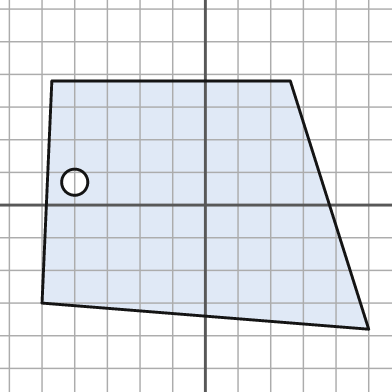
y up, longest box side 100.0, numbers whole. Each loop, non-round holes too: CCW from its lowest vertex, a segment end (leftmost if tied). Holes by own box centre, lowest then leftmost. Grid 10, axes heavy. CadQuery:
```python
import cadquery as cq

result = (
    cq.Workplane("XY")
    .moveTo(50.0, -38.0)
    .lineTo(26.0, 38.0)
    .lineTo(-47.0, 38.0)
    .lineTo(-50.0, -30.0)
    .close()
    .moveTo(-40.0, 7.0)
    .circle(4.0)
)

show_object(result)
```